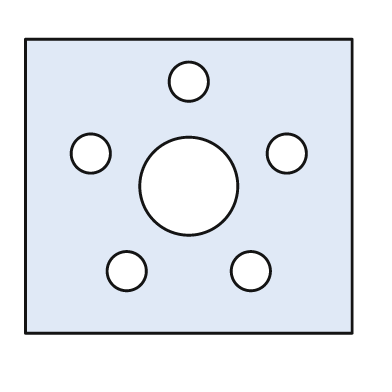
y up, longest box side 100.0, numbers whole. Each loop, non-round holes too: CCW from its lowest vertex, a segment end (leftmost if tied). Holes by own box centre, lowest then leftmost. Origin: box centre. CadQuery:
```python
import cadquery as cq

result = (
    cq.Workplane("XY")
    .moveTo(-50.0, -45.0)
    .lineTo(50.0, -45.0)
    .lineTo(50.0, 45.0)
    .lineTo(-50.0, 45.0)
    .close()
    .moveTo(-19.0, -26.0)
    .circle(6.0)
    .moveTo(19.0, -26.0)
    .circle(6.0)
    .moveTo(0.0, 0.0)
    .circle(15.0)
    .moveTo(-30.0, 10.0)
    .circle(6.0)
    .moveTo(30.0, 10.0)
    .circle(6.0)
    .moveTo(0.0, 32.0)
    .circle(6.0)
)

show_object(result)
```